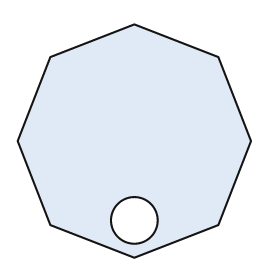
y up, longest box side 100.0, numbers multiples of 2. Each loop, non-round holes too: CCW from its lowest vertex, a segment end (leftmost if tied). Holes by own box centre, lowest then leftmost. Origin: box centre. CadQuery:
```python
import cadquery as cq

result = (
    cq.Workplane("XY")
    .moveTo(0.0, -50.0)
    .lineTo(36.0, -36.0)
    .lineTo(50.0, 0.0)
    .lineTo(36.0, 36.0)
    .lineTo(0.0, 50.0)
    .lineTo(-36.0, 36.0)
    .lineTo(-50.0, 0.0)
    .lineTo(-36.0, -36.0)
    .close()
    .moveTo(0.0, -34.0)
    .circle(10.0)
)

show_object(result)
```